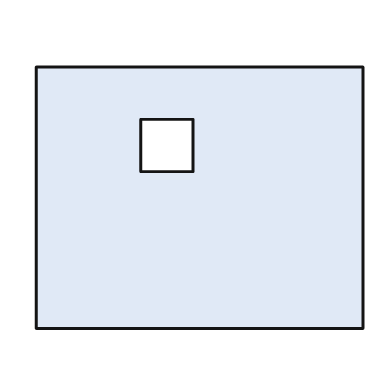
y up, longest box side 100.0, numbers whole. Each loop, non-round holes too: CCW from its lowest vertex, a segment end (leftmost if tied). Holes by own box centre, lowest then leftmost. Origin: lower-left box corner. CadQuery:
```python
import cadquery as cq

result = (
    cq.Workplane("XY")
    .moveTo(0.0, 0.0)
    .lineTo(100.0, 0.0)
    .lineTo(100.0, 80.0)
    .lineTo(0.0, 80.0)
    .close()
    .moveTo(32.0, 48.0)
    .lineTo(48.0, 48.0)
    .lineTo(48.0, 64.0)
    .lineTo(32.0, 64.0)
    .close()
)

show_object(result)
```